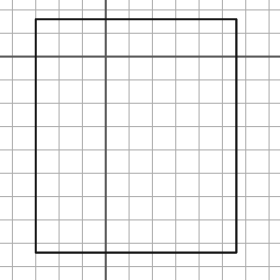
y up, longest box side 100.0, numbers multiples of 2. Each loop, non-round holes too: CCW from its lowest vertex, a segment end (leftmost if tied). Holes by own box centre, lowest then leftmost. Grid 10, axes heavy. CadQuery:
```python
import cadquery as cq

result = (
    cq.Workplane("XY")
    .moveTo(-30.0, -84.0)
    .lineTo(56.0, -84.0)
    .lineTo(56.0, 16.0)
    .lineTo(-30.0, 16.0)
    .close()
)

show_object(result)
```